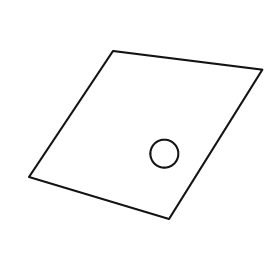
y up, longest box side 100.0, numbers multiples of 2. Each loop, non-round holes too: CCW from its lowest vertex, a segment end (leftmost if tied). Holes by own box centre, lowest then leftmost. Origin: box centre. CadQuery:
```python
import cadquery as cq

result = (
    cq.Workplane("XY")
    .moveTo(10.0, -36.0)
    .lineTo(50.0, 28.0)
    .lineTo(-14.0, 36.0)
    .lineTo(-50.0, -18.0)
    .close()
    .moveTo(8.0, -8.0)
    .circle(6.0)
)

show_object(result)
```